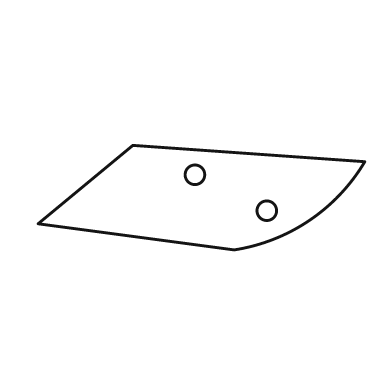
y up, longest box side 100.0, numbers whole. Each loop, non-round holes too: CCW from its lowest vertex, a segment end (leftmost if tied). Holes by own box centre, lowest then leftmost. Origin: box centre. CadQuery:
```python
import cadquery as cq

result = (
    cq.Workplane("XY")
    .moveTo(10.0, -16.0)
    .threePointArc((33.0, -7.0), (50.0, 11.0))
    .lineTo(-21.0, 16.0)
    .lineTo(-50.0, -8.0)
    .close()
    .moveTo(20.0, -4.0)
    .circle(3.0)
    .moveTo(-2.0, 7.0)
    .circle(3.0)
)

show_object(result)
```